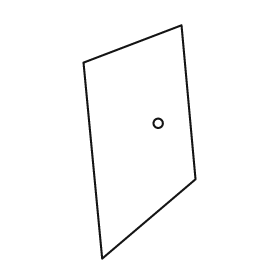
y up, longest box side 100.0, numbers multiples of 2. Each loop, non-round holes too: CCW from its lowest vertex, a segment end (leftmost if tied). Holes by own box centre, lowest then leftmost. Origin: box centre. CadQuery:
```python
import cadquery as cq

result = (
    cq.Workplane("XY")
    .moveTo(-16.0, -50.0)
    .lineTo(24.0, -16.0)
    .lineTo(18.0, 50.0)
    .lineTo(-24.0, 34.0)
    .close()
    .moveTo(8.0, 8.0)
    .circle(2.0)
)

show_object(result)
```